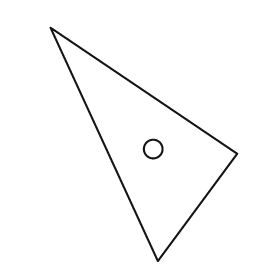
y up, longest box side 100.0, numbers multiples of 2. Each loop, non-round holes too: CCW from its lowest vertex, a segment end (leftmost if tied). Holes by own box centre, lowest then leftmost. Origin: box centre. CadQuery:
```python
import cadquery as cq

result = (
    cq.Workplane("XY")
    .moveTo(6.0, -50.0)
    .lineTo(40.0, -4.0)
    .lineTo(-40.0, 50.0)
    .close()
    .moveTo(4.0, -2.0)
    .circle(4.0)
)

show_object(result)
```